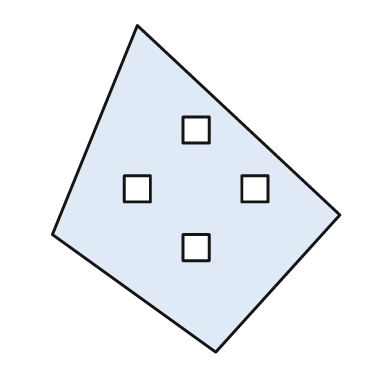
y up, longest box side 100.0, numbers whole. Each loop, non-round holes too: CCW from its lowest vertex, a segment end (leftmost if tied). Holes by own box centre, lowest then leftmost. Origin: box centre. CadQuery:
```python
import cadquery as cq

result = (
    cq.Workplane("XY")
    .moveTo(6.0, -50.0)
    .lineTo(44.0, -8.0)
    .lineTo(-18.0, 50.0)
    .lineTo(-44.0, -14.0)
    .close()
    .moveTo(-4.0, -22.0)
    .lineTo(4.0, -22.0)
    .lineTo(4.0, -14.0)
    .lineTo(-4.0, -14.0)
    .close()
    .moveTo(-22.0, -4.0)
    .lineTo(-14.0, -4.0)
    .lineTo(-14.0, 4.0)
    .lineTo(-22.0, 4.0)
    .close()
    .moveTo(14.0, -4.0)
    .lineTo(22.0, -4.0)
    .lineTo(22.0, 4.0)
    .lineTo(14.0, 4.0)
    .close()
    .moveTo(-4.0, 14.0)
    .lineTo(4.0, 14.0)
    .lineTo(4.0, 22.0)
    .lineTo(-4.0, 22.0)
    .close()
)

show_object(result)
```